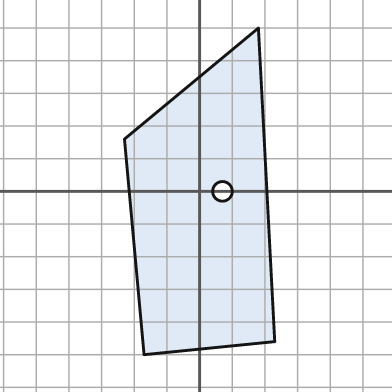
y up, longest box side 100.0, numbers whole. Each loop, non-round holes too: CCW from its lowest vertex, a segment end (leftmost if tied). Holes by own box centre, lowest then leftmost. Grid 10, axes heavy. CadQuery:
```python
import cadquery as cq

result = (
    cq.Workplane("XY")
    .moveTo(-17.0, -50.0)
    .lineTo(23.0, -46.0)
    .lineTo(18.0, 50.0)
    .lineTo(-23.0, 16.0)
    .close()
    .moveTo(7.0, 0.0)
    .circle(3.0)
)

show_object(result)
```